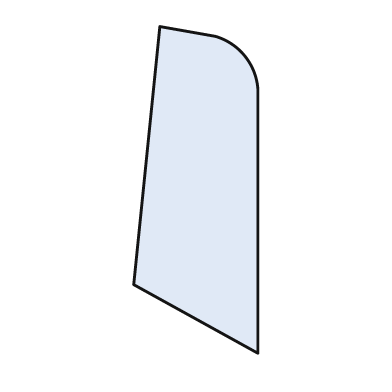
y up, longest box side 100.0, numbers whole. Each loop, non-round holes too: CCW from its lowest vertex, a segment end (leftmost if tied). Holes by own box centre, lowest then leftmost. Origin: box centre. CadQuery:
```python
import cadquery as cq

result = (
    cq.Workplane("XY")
    .moveTo(19.0, -50.0)
    .lineTo(19.0, 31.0)
    .threePointArc((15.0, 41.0), (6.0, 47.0))
    .lineTo(-11.0, 50.0)
    .lineTo(-19.0, -29.0)
    .close()
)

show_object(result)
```